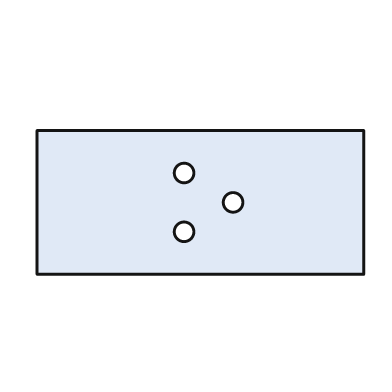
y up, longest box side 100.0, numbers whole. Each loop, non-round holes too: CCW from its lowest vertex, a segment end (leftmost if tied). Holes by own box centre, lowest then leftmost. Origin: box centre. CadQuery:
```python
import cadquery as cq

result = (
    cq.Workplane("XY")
    .moveTo(-50.0, -22.0)
    .lineTo(50.0, -22.0)
    .lineTo(50.0, 22.0)
    .lineTo(-50.0, 22.0)
    .close()
    .moveTo(-5.0, -9.0)
    .circle(3.0)
    .moveTo(10.0, 0.0)
    .circle(3.0)
    .moveTo(-5.0, 9.0)
    .circle(3.0)
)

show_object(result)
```